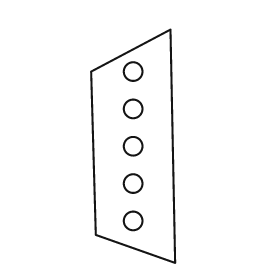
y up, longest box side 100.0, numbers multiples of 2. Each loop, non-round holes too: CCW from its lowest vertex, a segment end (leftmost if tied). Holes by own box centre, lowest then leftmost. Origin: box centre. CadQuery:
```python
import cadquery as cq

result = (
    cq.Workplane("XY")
    .moveTo(18.0, -50.0)
    .lineTo(16.0, 50.0)
    .lineTo(-18.0, 32.0)
    .lineTo(-16.0, -38.0)
    .close()
    .moveTo(0.0, -32.0)
    .circle(4.0)
    .moveTo(0.0, -16.0)
    .circle(4.0)
    .moveTo(0.0, 0.0)
    .circle(4.0)
    .moveTo(0.0, 16.0)
    .circle(4.0)
    .moveTo(0.0, 32.0)
    .circle(4.0)
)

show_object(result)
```